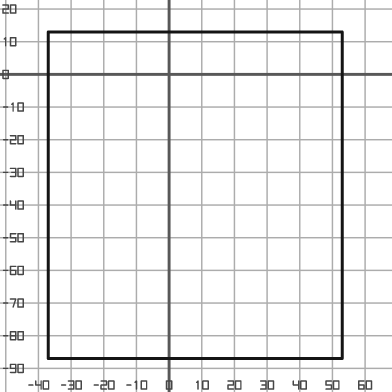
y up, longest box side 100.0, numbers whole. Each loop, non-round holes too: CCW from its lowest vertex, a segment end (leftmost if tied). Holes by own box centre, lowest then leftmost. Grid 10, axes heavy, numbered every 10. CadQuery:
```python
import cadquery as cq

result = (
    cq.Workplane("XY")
    .moveTo(-37.0, -87.0)
    .lineTo(53.0, -87.0)
    .lineTo(53.0, 13.0)
    .lineTo(-37.0, 13.0)
    .close()
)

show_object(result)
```